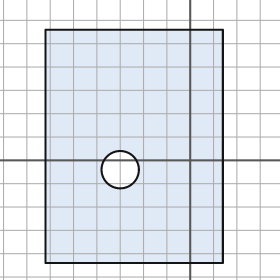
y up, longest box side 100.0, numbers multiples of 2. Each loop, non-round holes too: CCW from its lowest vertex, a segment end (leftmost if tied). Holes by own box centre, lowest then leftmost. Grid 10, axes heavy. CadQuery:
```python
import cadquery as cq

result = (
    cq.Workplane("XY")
    .moveTo(-62.0, -44.0)
    .lineTo(14.0, -44.0)
    .lineTo(14.0, 56.0)
    .lineTo(-62.0, 56.0)
    .close()
    .moveTo(-30.0, -4.0)
    .circle(8.0)
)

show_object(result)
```